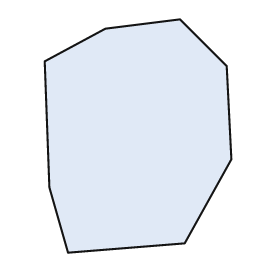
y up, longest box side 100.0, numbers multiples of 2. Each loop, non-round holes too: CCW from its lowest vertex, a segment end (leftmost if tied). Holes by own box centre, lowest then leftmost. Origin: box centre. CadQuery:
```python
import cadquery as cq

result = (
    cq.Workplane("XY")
    .moveTo(-30.0, -50.0)
    .lineTo(20.0, -46.0)
    .lineTo(40.0, -10.0)
    .lineTo(38.0, 30.0)
    .lineTo(18.0, 50.0)
    .lineTo(-14.0, 46.0)
    .lineTo(-40.0, 32.0)
    .lineTo(-38.0, -22.0)
    .close()
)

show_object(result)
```